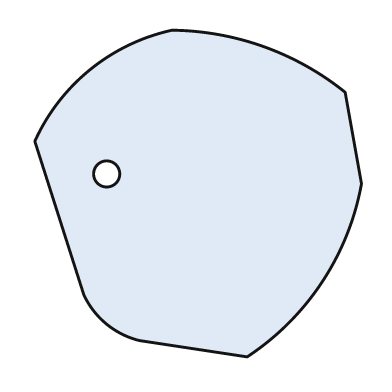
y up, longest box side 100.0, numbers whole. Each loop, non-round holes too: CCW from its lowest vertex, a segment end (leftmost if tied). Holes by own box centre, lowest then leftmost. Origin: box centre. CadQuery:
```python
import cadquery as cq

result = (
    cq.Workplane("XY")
    .moveTo(15.0, -50.0)
    .threePointArc((38.0, -27.0), (50.0, 3.0))
    .lineTo(45.0, 31.0)
    .threePointArc((20.0, 45.0), (-8.0, 50.0))
    .threePointArc((-33.0, 38.0), (-50.0, 16.0))
    .lineTo(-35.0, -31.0)
    .threePointArc((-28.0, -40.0), (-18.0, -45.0))
    .close()
    .moveTo(-28.0, 6.0)
    .circle(4.0)
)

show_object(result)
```